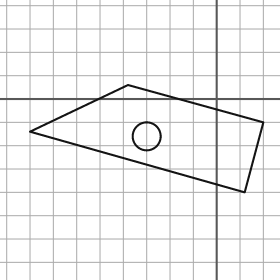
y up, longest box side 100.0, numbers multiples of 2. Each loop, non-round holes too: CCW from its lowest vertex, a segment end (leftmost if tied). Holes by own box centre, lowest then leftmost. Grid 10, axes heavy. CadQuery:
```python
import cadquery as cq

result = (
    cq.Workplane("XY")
    .moveTo(12.0, -40.0)
    .lineTo(20.0, -10.0)
    .lineTo(-38.0, 6.0)
    .lineTo(-80.0, -14.0)
    .close()
    .moveTo(-30.0, -16.0)
    .circle(6.0)
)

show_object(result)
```